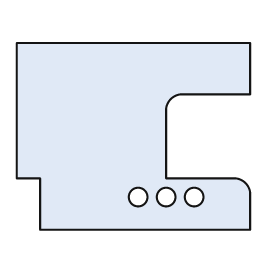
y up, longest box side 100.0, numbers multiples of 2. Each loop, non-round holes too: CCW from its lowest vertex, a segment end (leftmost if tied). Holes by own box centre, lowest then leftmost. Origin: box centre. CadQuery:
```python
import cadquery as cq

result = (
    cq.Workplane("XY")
    .moveTo(-40.0, -40.0)
    .lineTo(50.0, -40.0)
    .lineTo(50.0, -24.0)
    .threePointArc((48.0, -20.0), (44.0, -18.0))
    .lineTo(14.0, -18.0)
    .lineTo(14.0, 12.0)
    .threePointArc((16.0, 16.0), (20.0, 18.0))
    .lineTo(50.0, 18.0)
    .lineTo(50.0, 40.0)
    .lineTo(-50.0, 40.0)
    .lineTo(-50.0, -18.0)
    .lineTo(-40.0, -18.0)
    .close()
    .moveTo(2.0, -26.0)
    .circle(4.0)
    .moveTo(14.0, -26.0)
    .circle(4.0)
    .moveTo(26.0, -26.0)
    .circle(4.0)
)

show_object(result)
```